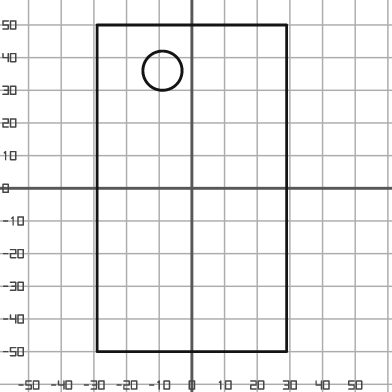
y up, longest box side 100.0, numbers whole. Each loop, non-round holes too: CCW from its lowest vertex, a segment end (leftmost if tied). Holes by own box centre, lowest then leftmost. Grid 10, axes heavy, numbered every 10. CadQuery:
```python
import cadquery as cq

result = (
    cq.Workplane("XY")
    .moveTo(-29.0, -50.0)
    .lineTo(29.0, -50.0)
    .lineTo(29.0, 50.0)
    .lineTo(-29.0, 50.0)
    .close()
    .moveTo(-9.0, 36.0)
    .circle(6.0)
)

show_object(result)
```